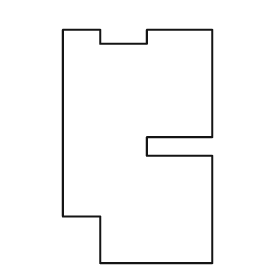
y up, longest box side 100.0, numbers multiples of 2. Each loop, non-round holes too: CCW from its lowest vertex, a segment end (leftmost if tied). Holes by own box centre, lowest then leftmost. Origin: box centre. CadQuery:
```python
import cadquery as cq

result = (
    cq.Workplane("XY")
    .moveTo(-16.0, -50.0)
    .lineTo(32.0, -50.0)
    .lineTo(32.0, -4.0)
    .lineTo(4.0, -4.0)
    .lineTo(4.0, 4.0)
    .lineTo(32.0, 4.0)
    .lineTo(32.0, 50.0)
    .lineTo(4.0, 50.0)
    .lineTo(4.0, 44.0)
    .lineTo(-16.0, 44.0)
    .lineTo(-16.0, 50.0)
    .lineTo(-32.0, 50.0)
    .lineTo(-32.0, -30.0)
    .lineTo(-16.0, -30.0)
    .close()
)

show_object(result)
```